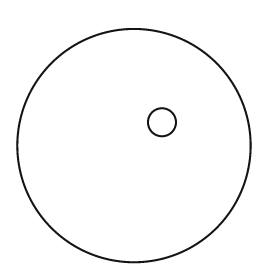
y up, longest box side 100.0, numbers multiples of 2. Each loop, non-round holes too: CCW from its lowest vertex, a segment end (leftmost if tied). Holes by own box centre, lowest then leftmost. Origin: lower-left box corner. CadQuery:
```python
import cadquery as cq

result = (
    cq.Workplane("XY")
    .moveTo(50.0, 50.0)
    .circle(50.0)
    .moveTo(62.0, 60.0)
    .circle(6.0)
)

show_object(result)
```